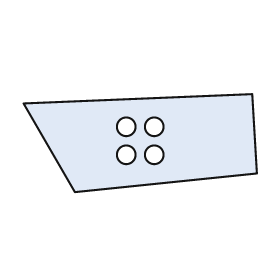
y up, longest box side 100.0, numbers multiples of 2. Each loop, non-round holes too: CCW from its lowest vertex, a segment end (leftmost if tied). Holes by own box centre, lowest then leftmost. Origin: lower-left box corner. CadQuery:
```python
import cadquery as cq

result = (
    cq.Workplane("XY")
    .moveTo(22.0, 0.0)
    .lineTo(100.0, 8.0)
    .lineTo(98.0, 42.0)
    .lineTo(0.0, 38.0)
    .close()
    .moveTo(44.0, 16.0)
    .circle(4.0)
    .moveTo(56.0, 16.0)
    .circle(4.0)
    .moveTo(44.0, 28.0)
    .circle(4.0)
    .moveTo(56.0, 28.0)
    .circle(4.0)
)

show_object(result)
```